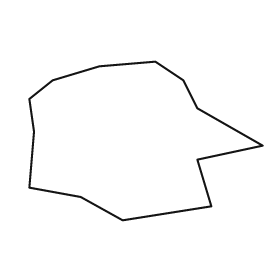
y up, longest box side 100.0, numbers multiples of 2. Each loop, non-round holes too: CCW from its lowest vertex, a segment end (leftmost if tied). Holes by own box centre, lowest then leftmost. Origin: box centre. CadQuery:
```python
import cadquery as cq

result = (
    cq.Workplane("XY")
    .moveTo(-10.0, -34.0)
    .lineTo(28.0, -28.0)
    .lineTo(22.0, -8.0)
    .lineTo(50.0, -2.0)
    .lineTo(22.0, 14.0)
    .lineTo(16.0, 26.0)
    .lineTo(4.0, 34.0)
    .lineTo(-20.0, 32.0)
    .lineTo(-40.0, 26.0)
    .lineTo(-50.0, 18.0)
    .lineTo(-48.0, 4.0)
    .lineTo(-50.0, -20.0)
    .lineTo(-28.0, -24.0)
    .close()
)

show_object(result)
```